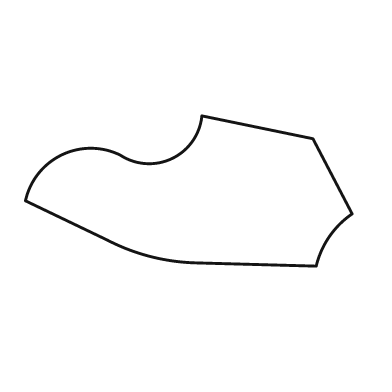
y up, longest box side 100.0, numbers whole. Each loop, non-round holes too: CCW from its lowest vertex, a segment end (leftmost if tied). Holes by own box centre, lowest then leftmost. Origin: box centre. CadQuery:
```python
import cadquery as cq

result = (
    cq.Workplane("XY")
    .moveTo(39.0, -23.0)
    .threePointArc((43.0, -14.0), (50.0, -7.0))
    .lineTo(38.0, 16.0)
    .lineTo(4.0, 23.0)
    .threePointArc((-5.0, 10.0), (-21.0, 11.0))
    .threePointArc((-39.0, 11.0), (-50.0, -3.0))
    .lineTo(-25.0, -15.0)
    .threePointArc((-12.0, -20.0), (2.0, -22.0))
    .close()
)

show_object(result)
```